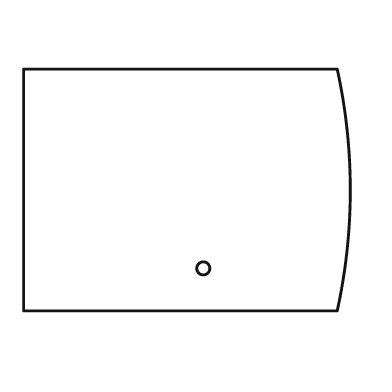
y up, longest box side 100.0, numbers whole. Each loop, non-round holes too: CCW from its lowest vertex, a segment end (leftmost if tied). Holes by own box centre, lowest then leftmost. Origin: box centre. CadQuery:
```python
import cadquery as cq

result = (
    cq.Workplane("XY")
    .moveTo(-50.0, -37.0)
    .lineTo(46.0, -37.0)
    .threePointArc((50.0, 0.0), (46.0, 37.0))
    .lineTo(-50.0, 37.0)
    .close()
    .moveTo(5.0, -24.0)
    .circle(2.0)
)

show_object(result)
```